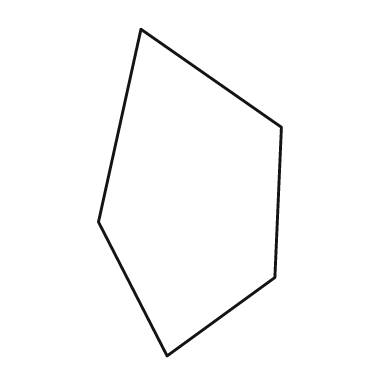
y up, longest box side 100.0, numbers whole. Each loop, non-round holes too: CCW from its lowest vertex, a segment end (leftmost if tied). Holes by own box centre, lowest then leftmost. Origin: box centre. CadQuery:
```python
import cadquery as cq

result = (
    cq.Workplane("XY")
    .moveTo(-7.0, -50.0)
    .lineTo(26.0, -26.0)
    .lineTo(28.0, 20.0)
    .lineTo(-15.0, 50.0)
    .lineTo(-28.0, -9.0)
    .close()
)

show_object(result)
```